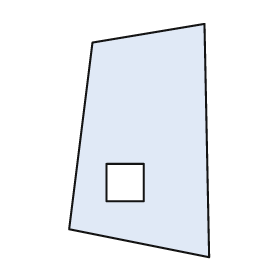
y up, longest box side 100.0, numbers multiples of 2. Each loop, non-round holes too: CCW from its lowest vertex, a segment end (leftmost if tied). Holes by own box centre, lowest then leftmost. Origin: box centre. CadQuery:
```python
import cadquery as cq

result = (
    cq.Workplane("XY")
    .moveTo(30.0, -50.0)
    .lineTo(28.0, 50.0)
    .lineTo(-20.0, 42.0)
    .lineTo(-30.0, -38.0)
    .close()
    .moveTo(-14.0, -26.0)
    .lineTo(2.0, -26.0)
    .lineTo(2.0, -10.0)
    .lineTo(-14.0, -10.0)
    .close()
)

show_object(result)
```